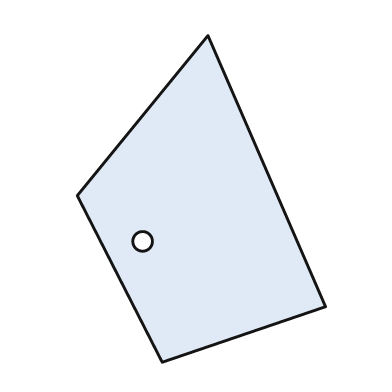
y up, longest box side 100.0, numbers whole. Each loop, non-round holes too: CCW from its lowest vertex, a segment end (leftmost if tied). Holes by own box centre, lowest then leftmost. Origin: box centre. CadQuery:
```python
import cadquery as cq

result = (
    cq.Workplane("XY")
    .moveTo(-12.0, -50.0)
    .lineTo(38.0, -33.0)
    .lineTo(2.0, 50.0)
    .lineTo(-38.0, 1.0)
    .close()
    .moveTo(-18.0, -13.0)
    .circle(3.0)
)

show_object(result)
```